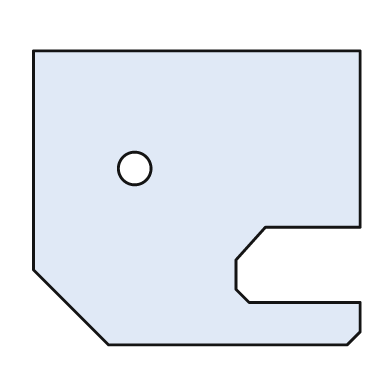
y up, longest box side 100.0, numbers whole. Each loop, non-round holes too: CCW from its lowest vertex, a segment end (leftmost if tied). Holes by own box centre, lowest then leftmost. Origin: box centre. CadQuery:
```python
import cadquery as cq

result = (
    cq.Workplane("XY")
    .moveTo(-27.0, -45.0)
    .lineTo(46.0, -45.0)
    .lineTo(50.0, -41.0)
    .lineTo(50.0, -32.0)
    .lineTo(16.0, -32.0)
    .lineTo(12.0, -28.0)
    .lineTo(12.0, -19.0)
    .lineTo(21.0, -9.0)
    .lineTo(50.0, -9.0)
    .lineTo(50.0, 45.0)
    .lineTo(-50.0, 45.0)
    .lineTo(-50.0, -22.0)
    .close()
    .moveTo(-19.0, 9.0)
    .circle(5.0)
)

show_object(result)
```